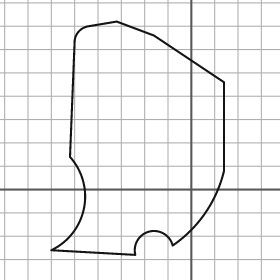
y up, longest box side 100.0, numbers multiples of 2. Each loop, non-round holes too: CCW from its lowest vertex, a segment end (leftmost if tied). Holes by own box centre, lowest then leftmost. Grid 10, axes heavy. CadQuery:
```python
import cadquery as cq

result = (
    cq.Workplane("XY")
    .moveTo(-24.0, -28.0)
    .threePointArc((-18.0, -18.0), (-8.0, -24.0))
    .threePointArc((6.0, -10.0), (14.0, 8.0))
    .lineTo(14.0, 46.0)
    .lineTo(-16.0, 66.0)
    .lineTo(-32.0, 72.0)
    .lineTo(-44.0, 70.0)
    .threePointArc((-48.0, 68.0), (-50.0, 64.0))
    .lineTo(-52.0, 14.0)
    .threePointArc((-46.0, -8.0), (-60.0, -26.0))
    .close()
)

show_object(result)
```